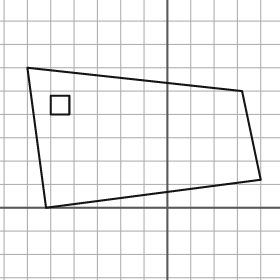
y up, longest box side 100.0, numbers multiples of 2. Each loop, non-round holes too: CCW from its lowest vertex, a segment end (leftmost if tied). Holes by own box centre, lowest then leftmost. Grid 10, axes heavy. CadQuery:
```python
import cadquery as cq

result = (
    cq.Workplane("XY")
    .moveTo(-52.0, 0.0)
    .lineTo(40.0, 12.0)
    .lineTo(32.0, 50.0)
    .lineTo(-60.0, 60.0)
    .close()
    .moveTo(-50.0, 40.0)
    .lineTo(-42.0, 40.0)
    .lineTo(-42.0, 48.0)
    .lineTo(-50.0, 48.0)
    .close()
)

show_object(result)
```